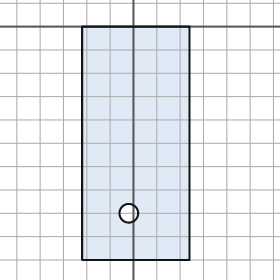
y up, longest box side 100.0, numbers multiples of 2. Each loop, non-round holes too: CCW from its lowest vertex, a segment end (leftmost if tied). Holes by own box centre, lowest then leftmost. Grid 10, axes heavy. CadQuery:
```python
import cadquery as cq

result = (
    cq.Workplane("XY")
    .moveTo(-22.0, -100.0)
    .lineTo(24.0, -100.0)
    .lineTo(24.0, 0.0)
    .lineTo(-22.0, 0.0)
    .close()
    .moveTo(-2.0, -80.0)
    .circle(4.0)
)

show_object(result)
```